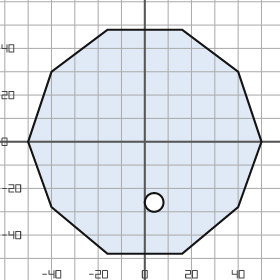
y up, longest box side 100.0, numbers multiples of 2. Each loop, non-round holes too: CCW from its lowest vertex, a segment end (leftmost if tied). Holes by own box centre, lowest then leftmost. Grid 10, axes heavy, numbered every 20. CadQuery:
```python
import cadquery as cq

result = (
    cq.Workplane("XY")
    .moveTo(-16.0, -48.0)
    .lineTo(16.0, -48.0)
    .lineTo(40.0, -28.0)
    .lineTo(50.0, 0.0)
    .lineTo(40.0, 30.0)
    .lineTo(16.0, 48.0)
    .lineTo(-16.0, 48.0)
    .lineTo(-40.0, 30.0)
    .lineTo(-50.0, 0.0)
    .lineTo(-40.0, -28.0)
    .close()
    .moveTo(4.0, -26.0)
    .circle(4.0)
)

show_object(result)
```